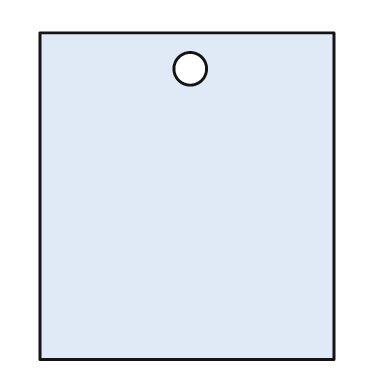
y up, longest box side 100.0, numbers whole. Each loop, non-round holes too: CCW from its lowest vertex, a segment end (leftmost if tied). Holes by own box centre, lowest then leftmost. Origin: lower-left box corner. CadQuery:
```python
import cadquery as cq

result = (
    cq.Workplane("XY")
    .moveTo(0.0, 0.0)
    .lineTo(90.0, 0.0)
    .lineTo(90.0, 100.0)
    .lineTo(0.0, 100.0)
    .close()
    .moveTo(46.0, 89.0)
    .circle(5.0)
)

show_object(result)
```